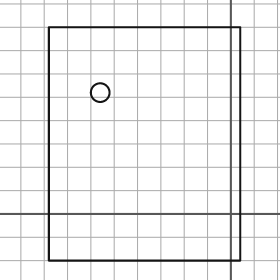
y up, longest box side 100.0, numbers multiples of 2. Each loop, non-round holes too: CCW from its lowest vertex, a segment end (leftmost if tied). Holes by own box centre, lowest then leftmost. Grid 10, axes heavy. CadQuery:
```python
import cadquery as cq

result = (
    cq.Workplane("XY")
    .moveTo(-78.0, -20.0)
    .lineTo(4.0, -20.0)
    .lineTo(4.0, 80.0)
    .lineTo(-78.0, 80.0)
    .close()
    .moveTo(-56.0, 52.0)
    .circle(4.0)
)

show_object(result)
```